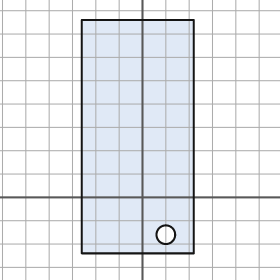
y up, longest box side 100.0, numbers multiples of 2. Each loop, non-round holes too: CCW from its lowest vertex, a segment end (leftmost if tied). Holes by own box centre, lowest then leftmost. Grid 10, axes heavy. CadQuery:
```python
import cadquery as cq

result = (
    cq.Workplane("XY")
    .moveTo(-26.0, -24.0)
    .lineTo(22.0, -24.0)
    .lineTo(22.0, 76.0)
    .lineTo(-26.0, 76.0)
    .close()
    .moveTo(10.0, -16.0)
    .circle(4.0)
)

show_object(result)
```